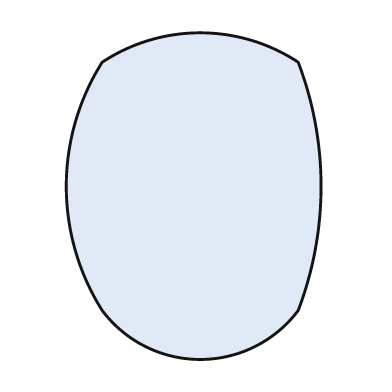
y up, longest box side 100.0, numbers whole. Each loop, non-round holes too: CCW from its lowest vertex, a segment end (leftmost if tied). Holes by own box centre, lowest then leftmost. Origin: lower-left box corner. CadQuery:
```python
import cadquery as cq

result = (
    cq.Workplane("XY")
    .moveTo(11.0, 15.0)
    .threePointArc((41.0, 0.0), (71.0, 15.0))
    .threePointArc((78.0, 53.0), (71.0, 91.0))
    .threePointArc((41.0, 100.0), (11.0, 91.0))
    .threePointArc((0.0, 53.0), (11.0, 15.0))
    .close()
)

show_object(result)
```